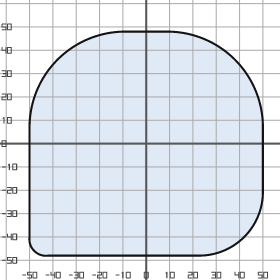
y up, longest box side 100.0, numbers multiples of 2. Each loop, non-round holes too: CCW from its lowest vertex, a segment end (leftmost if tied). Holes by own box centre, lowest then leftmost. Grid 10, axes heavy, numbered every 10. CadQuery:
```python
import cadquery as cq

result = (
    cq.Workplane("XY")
    .moveTo(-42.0, -48.0)
    .lineTo(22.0, -48.0)
    .threePointArc((42.0, -40.0), (50.0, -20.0))
    .lineTo(50.0, 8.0)
    .threePointArc((38.0, 36.0), (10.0, 48.0))
    .lineTo(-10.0, 48.0)
    .threePointArc((-38.0, 36.0), (-50.0, 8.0))
    .lineTo(-50.0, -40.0)
    .threePointArc((-48.0, -46.0), (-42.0, -48.0))
    .close()
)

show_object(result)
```